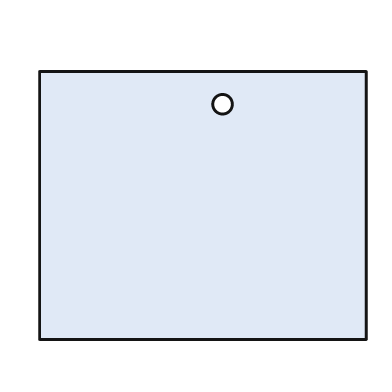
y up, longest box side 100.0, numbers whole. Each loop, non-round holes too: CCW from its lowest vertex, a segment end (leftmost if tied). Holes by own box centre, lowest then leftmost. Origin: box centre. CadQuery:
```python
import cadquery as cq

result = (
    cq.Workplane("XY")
    .moveTo(-50.0, -41.0)
    .lineTo(50.0, -41.0)
    .lineTo(50.0, 41.0)
    .lineTo(-50.0, 41.0)
    .close()
    .moveTo(6.0, 31.0)
    .circle(3.0)
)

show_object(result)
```